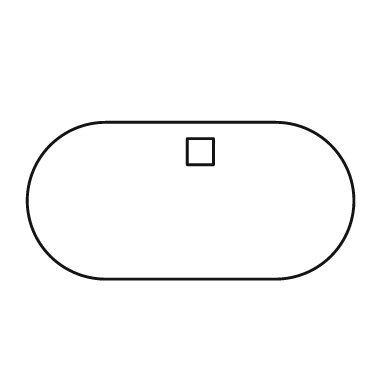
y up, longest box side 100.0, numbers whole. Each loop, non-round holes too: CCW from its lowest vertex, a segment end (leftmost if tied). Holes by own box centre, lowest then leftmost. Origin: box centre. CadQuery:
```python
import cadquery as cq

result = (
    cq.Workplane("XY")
    .moveTo(-26.0, -24.0)
    .lineTo(26.0, -24.0)
    .threePointArc((50.0, 0.0), (26.0, 24.0))
    .lineTo(-26.0, 24.0)
    .threePointArc((-50.0, 0.0), (-26.0, -24.0))
    .close()
    .moveTo(-1.0, 11.0)
    .lineTo(7.0, 11.0)
    .lineTo(7.0, 19.0)
    .lineTo(-1.0, 19.0)
    .close()
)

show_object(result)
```